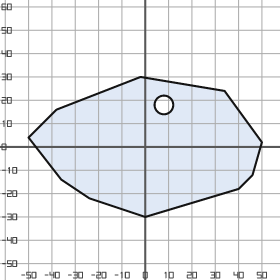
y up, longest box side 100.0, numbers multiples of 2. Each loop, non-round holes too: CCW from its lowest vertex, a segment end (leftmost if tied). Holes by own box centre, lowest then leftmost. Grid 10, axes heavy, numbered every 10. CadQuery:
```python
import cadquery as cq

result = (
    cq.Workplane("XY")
    .moveTo(0.0, -30.0)
    .lineTo(40.0, -18.0)
    .lineTo(46.0, -12.0)
    .lineTo(50.0, 2.0)
    .lineTo(34.0, 24.0)
    .lineTo(-2.0, 30.0)
    .lineTo(-38.0, 16.0)
    .lineTo(-50.0, 4.0)
    .lineTo(-36.0, -14.0)
    .lineTo(-24.0, -22.0)
    .close()
    .moveTo(8.0, 18.0)
    .circle(4.0)
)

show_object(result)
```